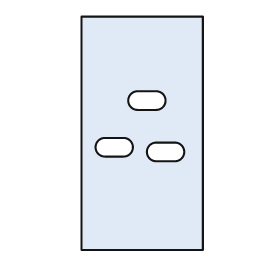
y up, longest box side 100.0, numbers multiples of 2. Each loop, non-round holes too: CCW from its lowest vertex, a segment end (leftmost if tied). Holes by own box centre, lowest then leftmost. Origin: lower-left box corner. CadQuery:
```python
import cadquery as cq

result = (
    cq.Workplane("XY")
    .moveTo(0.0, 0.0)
    .lineTo(52.0, 0.0)
    .lineTo(52.0, 100.0)
    .lineTo(0.0, 100.0)
    .close()
    .moveTo(32.0, 38.0)
    .lineTo(40.0, 38.0)
    .threePointArc((44.0, 42.0), (40.0, 46.0))
    .lineTo(32.0, 46.0)
    .threePointArc((28.0, 42.0), (32.0, 38.0))
    .close()
    .moveTo(10.0, 40.0)
    .lineTo(18.0, 40.0)
    .threePointArc((22.0, 44.0), (18.0, 48.0))
    .lineTo(10.0, 48.0)
    .threePointArc((6.0, 44.0), (10.0, 40.0))
    .close()
    .moveTo(24.0, 60.0)
    .lineTo(32.0, 60.0)
    .threePointArc((36.0, 64.0), (32.0, 68.0))
    .lineTo(24.0, 68.0)
    .threePointArc((20.0, 64.0), (24.0, 60.0))
    .close()
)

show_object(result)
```